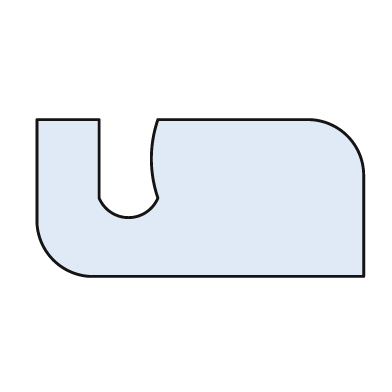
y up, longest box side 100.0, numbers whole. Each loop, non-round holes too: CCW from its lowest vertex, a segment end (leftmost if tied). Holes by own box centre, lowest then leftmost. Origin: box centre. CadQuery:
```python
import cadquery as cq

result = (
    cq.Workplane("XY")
    .moveTo(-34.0, -24.0)
    .lineTo(50.0, -24.0)
    .lineTo(50.0, 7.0)
    .threePointArc((45.0, 19.0), (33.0, 24.0))
    .lineTo(-13.0, 24.0)
    .threePointArc((-15.0, 12.0), (-13.0, 0.0))
    .threePointArc((-22.0, -6.0), (-31.0, 0.0))
    .lineTo(-31.0, 24.0)
    .lineTo(-50.0, 24.0)
    .lineTo(-50.0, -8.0)
    .threePointArc((-45.0, -19.0), (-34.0, -24.0))
    .close()
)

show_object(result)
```